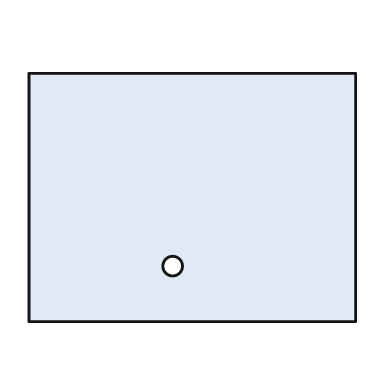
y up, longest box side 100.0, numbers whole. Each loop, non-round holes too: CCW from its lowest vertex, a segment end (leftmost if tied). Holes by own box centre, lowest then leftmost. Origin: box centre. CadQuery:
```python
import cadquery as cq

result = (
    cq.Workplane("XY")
    .moveTo(-50.0, -38.0)
    .lineTo(50.0, -38.0)
    .lineTo(50.0, 38.0)
    .lineTo(-50.0, 38.0)
    .close()
    .moveTo(-6.0, -21.0)
    .circle(3.0)
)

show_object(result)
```